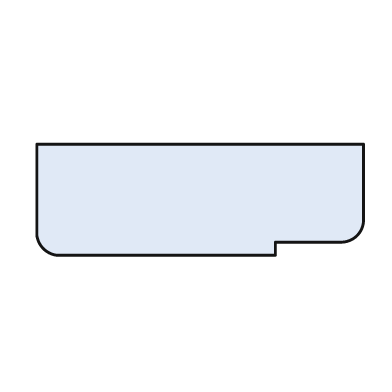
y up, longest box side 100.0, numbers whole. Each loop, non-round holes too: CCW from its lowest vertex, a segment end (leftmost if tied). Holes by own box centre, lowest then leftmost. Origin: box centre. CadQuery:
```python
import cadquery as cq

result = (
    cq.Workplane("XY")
    .moveTo(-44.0, -17.0)
    .lineTo(23.0, -17.0)
    .lineTo(23.0, -13.0)
    .lineTo(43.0, -13.0)
    .threePointArc((48.0, -11.0), (50.0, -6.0))
    .lineTo(50.0, 17.0)
    .lineTo(-50.0, 17.0)
    .lineTo(-50.0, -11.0)
    .threePointArc((-48.0, -15.0), (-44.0, -17.0))
    .close()
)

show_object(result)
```